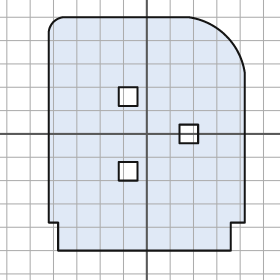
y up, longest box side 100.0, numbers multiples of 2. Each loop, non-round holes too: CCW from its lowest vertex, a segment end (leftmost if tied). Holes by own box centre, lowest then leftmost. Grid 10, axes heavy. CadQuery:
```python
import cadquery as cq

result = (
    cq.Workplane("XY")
    .moveTo(-38.0, -50.0)
    .lineTo(36.0, -50.0)
    .lineTo(36.0, -38.0)
    .lineTo(42.0, -38.0)
    .lineTo(42.0, 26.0)
    .threePointArc((34.0, 42.0), (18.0, 50.0))
    .lineTo(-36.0, 50.0)
    .threePointArc((-40.0, 48.0), (-42.0, 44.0))
    .lineTo(-42.0, -38.0)
    .lineTo(-38.0, -38.0)
    .close()
    .moveTo(-12.0, -20.0)
    .lineTo(-4.0, -20.0)
    .lineTo(-4.0, -12.0)
    .lineTo(-12.0, -12.0)
    .close()
    .moveTo(14.0, -4.0)
    .lineTo(22.0, -4.0)
    .lineTo(22.0, 4.0)
    .lineTo(14.0, 4.0)
    .close()
    .moveTo(-12.0, 12.0)
    .lineTo(-4.0, 12.0)
    .lineTo(-4.0, 20.0)
    .lineTo(-12.0, 20.0)
    .close()
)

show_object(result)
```